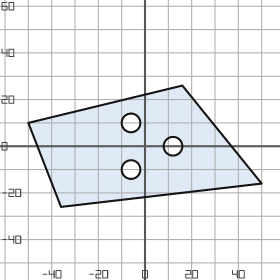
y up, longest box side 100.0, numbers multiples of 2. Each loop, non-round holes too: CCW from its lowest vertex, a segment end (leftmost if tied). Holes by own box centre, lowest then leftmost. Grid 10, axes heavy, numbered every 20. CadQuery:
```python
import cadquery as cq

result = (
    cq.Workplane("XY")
    .moveTo(-36.0, -26.0)
    .lineTo(50.0, -16.0)
    .lineTo(16.0, 26.0)
    .lineTo(-50.0, 10.0)
    .close()
    .moveTo(-6.0, -10.0)
    .circle(4.0)
    .moveTo(12.0, 0.0)
    .circle(4.0)
    .moveTo(-6.0, 10.0)
    .circle(4.0)
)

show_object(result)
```